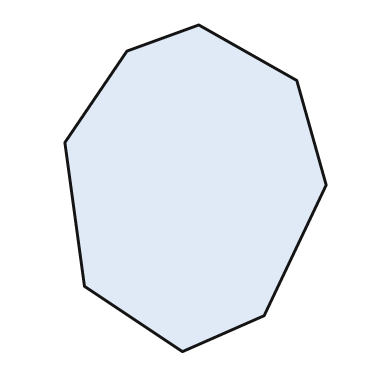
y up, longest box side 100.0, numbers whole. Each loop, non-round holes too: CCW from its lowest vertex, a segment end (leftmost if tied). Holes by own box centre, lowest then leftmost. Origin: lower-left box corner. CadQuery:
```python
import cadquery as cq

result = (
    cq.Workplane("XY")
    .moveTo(36.0, 0.0)
    .lineTo(61.0, 11.0)
    .lineTo(80.0, 51.0)
    .lineTo(71.0, 83.0)
    .lineTo(41.0, 100.0)
    .lineTo(19.0, 92.0)
    .lineTo(0.0, 64.0)
    .lineTo(6.0, 20.0)
    .close()
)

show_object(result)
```